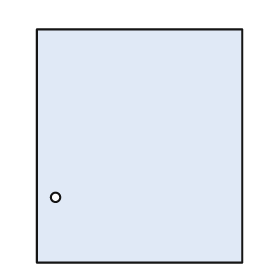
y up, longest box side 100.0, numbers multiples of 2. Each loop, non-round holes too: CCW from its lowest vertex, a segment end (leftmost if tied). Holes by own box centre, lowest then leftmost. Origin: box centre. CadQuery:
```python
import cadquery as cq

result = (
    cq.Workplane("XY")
    .moveTo(-44.0, -50.0)
    .lineTo(44.0, -50.0)
    .lineTo(44.0, 50.0)
    .lineTo(-44.0, 50.0)
    .close()
    .moveTo(-36.0, -22.0)
    .circle(2.0)
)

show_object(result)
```